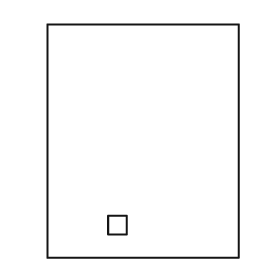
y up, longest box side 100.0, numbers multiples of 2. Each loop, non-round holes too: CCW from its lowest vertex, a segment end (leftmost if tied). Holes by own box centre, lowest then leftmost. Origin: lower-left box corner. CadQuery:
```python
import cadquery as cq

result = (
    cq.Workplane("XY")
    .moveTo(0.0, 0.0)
    .lineTo(82.0, 0.0)
    .lineTo(82.0, 100.0)
    .lineTo(0.0, 100.0)
    .close()
    .moveTo(26.0, 10.0)
    .lineTo(34.0, 10.0)
    .lineTo(34.0, 18.0)
    .lineTo(26.0, 18.0)
    .close()
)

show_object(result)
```